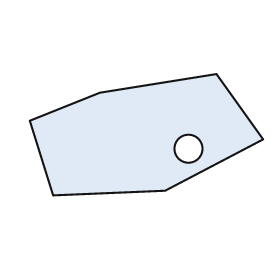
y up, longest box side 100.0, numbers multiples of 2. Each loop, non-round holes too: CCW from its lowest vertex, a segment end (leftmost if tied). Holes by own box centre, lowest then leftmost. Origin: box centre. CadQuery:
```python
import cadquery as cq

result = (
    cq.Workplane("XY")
    .moveTo(-40.0, -26.0)
    .lineTo(8.0, -24.0)
    .lineTo(50.0, -2.0)
    .lineTo(30.0, 26.0)
    .lineTo(-20.0, 18.0)
    .lineTo(-50.0, 6.0)
    .close()
    .moveTo(18.0, -6.0)
    .circle(6.0)
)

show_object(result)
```